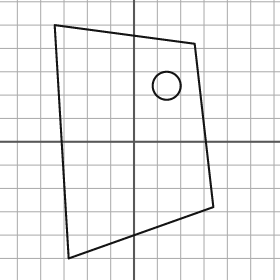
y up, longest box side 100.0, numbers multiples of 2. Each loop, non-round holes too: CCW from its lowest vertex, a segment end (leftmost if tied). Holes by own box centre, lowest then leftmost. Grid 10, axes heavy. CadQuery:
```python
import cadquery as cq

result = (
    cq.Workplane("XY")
    .moveTo(-28.0, -50.0)
    .lineTo(34.0, -28.0)
    .lineTo(26.0, 42.0)
    .lineTo(-34.0, 50.0)
    .close()
    .moveTo(14.0, 24.0)
    .circle(6.0)
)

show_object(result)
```